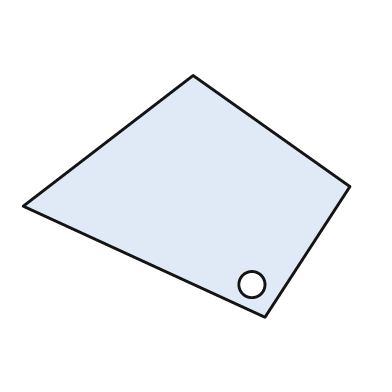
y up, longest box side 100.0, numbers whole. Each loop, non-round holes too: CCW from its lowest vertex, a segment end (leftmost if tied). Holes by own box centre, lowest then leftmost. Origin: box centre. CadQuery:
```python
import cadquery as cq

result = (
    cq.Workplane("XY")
    .moveTo(24.0, -37.0)
    .lineTo(50.0, 3.0)
    .lineTo(2.0, 37.0)
    .lineTo(-50.0, -3.0)
    .close()
    .moveTo(20.0, -27.0)
    .circle(4.0)
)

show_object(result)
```